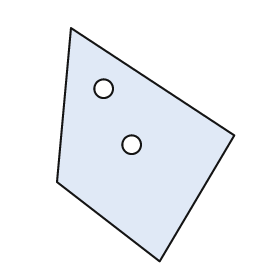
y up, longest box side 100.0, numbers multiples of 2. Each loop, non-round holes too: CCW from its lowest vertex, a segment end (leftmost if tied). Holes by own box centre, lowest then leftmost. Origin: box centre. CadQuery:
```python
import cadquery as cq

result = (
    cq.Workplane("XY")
    .moveTo(6.0, -50.0)
    .lineTo(38.0, 4.0)
    .lineTo(-32.0, 50.0)
    .lineTo(-38.0, -16.0)
    .close()
    .moveTo(-6.0, 0.0)
    .circle(4.0)
    .moveTo(-18.0, 24.0)
    .circle(4.0)
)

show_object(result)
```